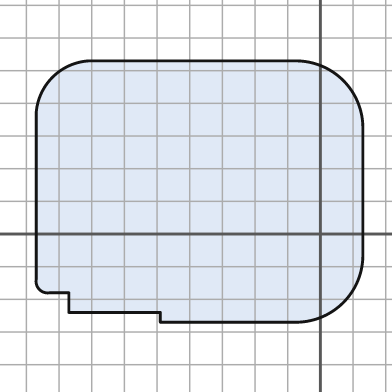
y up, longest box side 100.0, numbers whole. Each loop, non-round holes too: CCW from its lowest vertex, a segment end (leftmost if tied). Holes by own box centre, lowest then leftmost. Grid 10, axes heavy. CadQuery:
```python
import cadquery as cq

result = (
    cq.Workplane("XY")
    .moveTo(-49.0, -27.0)
    .lineTo(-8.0, -27.0)
    .threePointArc((7.0, -21.0), (13.0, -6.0))
    .lineTo(13.0, 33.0)
    .threePointArc((7.0, 47.0), (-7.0, 53.0))
    .lineTo(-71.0, 53.0)
    .threePointArc((-82.0, 48.0), (-87.0, 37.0))
    .lineTo(-87.0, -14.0)
    .threePointArc((-86.0, -17.0), (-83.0, -18.0))
    .lineTo(-77.0, -18.0)
    .lineTo(-77.0, -24.0)
    .lineTo(-49.0, -24.0)
    .close()
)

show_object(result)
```